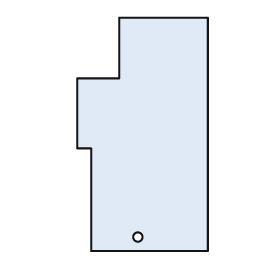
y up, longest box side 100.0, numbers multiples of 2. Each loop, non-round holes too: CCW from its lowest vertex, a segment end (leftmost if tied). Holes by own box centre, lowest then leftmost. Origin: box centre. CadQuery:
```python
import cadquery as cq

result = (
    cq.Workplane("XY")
    .moveTo(-22.0, -50.0)
    .lineTo(28.0, -50.0)
    .lineTo(28.0, 50.0)
    .lineTo(-10.0, 50.0)
    .lineTo(-10.0, 24.0)
    .lineTo(-28.0, 24.0)
    .lineTo(-28.0, -6.0)
    .lineTo(-22.0, -6.0)
    .close()
    .moveTo(-2.0, -44.0)
    .circle(2.0)
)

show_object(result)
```